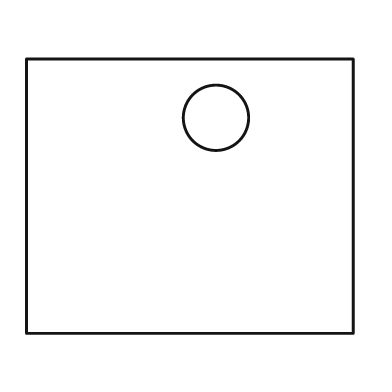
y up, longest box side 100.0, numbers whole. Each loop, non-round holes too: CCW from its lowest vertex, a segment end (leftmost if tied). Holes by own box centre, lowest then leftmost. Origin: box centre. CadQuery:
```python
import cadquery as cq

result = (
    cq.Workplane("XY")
    .moveTo(-50.0, -42.0)
    .lineTo(50.0, -42.0)
    .lineTo(50.0, 42.0)
    .lineTo(-50.0, 42.0)
    .close()
    .moveTo(8.0, 24.0)
    .circle(10.0)
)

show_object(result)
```